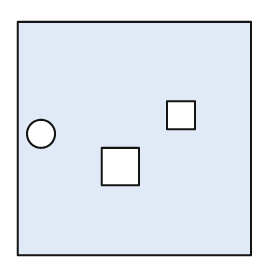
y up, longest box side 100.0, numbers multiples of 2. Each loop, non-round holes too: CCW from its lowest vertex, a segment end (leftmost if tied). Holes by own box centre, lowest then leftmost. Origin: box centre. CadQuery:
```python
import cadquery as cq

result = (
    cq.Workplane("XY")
    .moveTo(-50.0, -50.0)
    .lineTo(50.0, -50.0)
    .lineTo(50.0, 50.0)
    .lineTo(-50.0, 50.0)
    .close()
    .moveTo(-14.0, -20.0)
    .lineTo(2.0, -20.0)
    .lineTo(2.0, -4.0)
    .lineTo(-14.0, -4.0)
    .close()
    .moveTo(-40.0, 2.0)
    .circle(6.0)
    .moveTo(14.0, 4.0)
    .lineTo(26.0, 4.0)
    .lineTo(26.0, 16.0)
    .lineTo(14.0, 16.0)
    .close()
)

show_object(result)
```